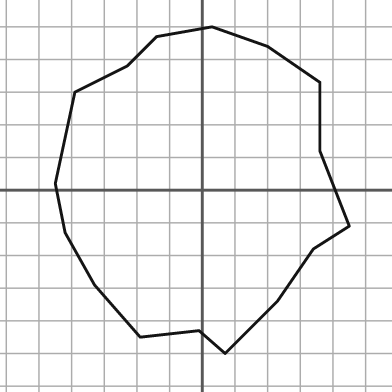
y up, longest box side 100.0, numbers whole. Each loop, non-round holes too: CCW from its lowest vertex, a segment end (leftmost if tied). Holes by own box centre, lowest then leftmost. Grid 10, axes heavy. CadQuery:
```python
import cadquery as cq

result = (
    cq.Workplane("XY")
    .moveTo(7.0, -50.0)
    .lineTo(23.0, -34.0)
    .lineTo(34.0, -18.0)
    .lineTo(45.0, -11.0)
    .lineTo(36.0, 12.0)
    .lineTo(36.0, 33.0)
    .lineTo(20.0, 44.0)
    .lineTo(3.0, 50.0)
    .lineTo(-14.0, 47.0)
    .lineTo(-23.0, 38.0)
    .lineTo(-39.0, 30.0)
    .lineTo(-45.0, 2.0)
    .lineTo(-42.0, -13.0)
    .lineTo(-33.0, -29.0)
    .lineTo(-19.0, -45.0)
    .lineTo(-1.0, -43.0)
    .close()
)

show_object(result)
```